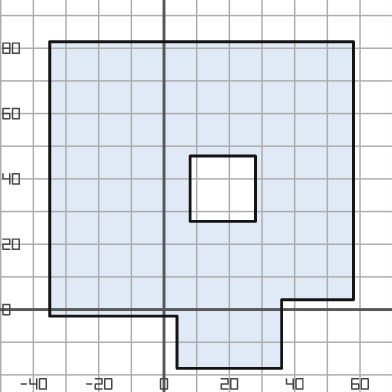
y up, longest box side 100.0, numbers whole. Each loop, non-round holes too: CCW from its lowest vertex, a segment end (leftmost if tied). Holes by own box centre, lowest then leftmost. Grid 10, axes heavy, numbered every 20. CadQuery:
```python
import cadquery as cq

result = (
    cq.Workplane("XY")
    .moveTo(4.0, -18.0)
    .lineTo(36.0, -18.0)
    .lineTo(36.0, 3.0)
    .lineTo(58.0, 3.0)
    .lineTo(58.0, 82.0)
    .lineTo(-35.0, 82.0)
    .lineTo(-35.0, -2.0)
    .lineTo(4.0, -2.0)
    .close()
    .moveTo(8.0, 27.0)
    .lineTo(28.0, 27.0)
    .lineTo(28.0, 47.0)
    .lineTo(8.0, 47.0)
    .close()
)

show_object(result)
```